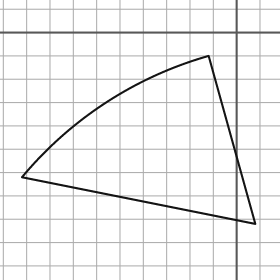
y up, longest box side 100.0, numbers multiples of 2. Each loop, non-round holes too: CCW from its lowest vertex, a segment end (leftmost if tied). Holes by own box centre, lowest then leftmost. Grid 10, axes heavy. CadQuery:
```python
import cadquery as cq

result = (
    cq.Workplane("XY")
    .moveTo(8.0, -82.0)
    .lineTo(-12.0, -10.0)
    .threePointArc((-56.0, -30.0), (-92.0, -62.0))
    .close()
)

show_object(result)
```